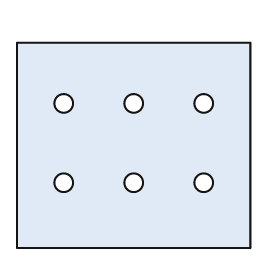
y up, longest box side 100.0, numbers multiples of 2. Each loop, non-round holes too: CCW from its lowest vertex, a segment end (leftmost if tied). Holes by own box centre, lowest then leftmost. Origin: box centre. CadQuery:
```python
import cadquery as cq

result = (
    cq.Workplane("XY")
    .moveTo(-50.0, -44.0)
    .lineTo(50.0, -44.0)
    .lineTo(50.0, 44.0)
    .lineTo(-50.0, 44.0)
    .close()
    .moveTo(-30.0, -16.0)
    .circle(4.0)
    .moveTo(0.0, -16.0)
    .circle(4.0)
    .moveTo(30.0, -16.0)
    .circle(4.0)
    .moveTo(-30.0, 18.0)
    .circle(4.0)
    .moveTo(0.0, 18.0)
    .circle(4.0)
    .moveTo(30.0, 18.0)
    .circle(4.0)
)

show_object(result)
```